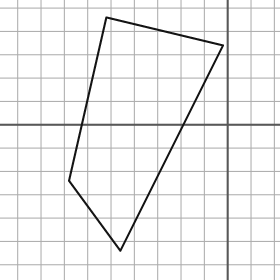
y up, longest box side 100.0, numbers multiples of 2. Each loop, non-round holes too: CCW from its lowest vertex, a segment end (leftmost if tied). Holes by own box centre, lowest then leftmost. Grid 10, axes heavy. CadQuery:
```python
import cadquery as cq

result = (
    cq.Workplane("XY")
    .moveTo(-46.0, -54.0)
    .lineTo(-2.0, 34.0)
    .lineTo(-52.0, 46.0)
    .lineTo(-68.0, -24.0)
    .close()
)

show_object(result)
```